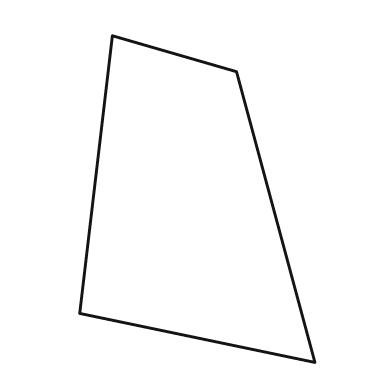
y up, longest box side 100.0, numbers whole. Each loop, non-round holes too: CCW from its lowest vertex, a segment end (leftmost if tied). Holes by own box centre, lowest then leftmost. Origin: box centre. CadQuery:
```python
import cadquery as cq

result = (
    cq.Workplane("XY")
    .moveTo(36.0, -50.0)
    .lineTo(12.0, 39.0)
    .lineTo(-26.0, 50.0)
    .lineTo(-36.0, -35.0)
    .close()
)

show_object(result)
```